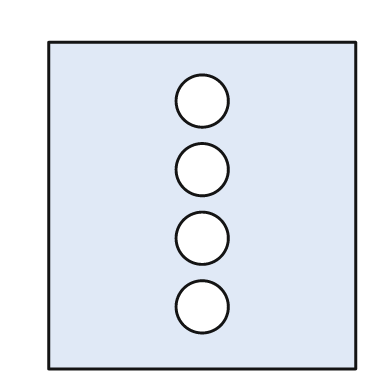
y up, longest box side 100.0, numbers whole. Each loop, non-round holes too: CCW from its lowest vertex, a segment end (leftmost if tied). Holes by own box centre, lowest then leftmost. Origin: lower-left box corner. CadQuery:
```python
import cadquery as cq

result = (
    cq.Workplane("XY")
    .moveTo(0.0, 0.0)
    .lineTo(94.0, 0.0)
    .lineTo(94.0, 100.0)
    .lineTo(0.0, 100.0)
    .close()
    .moveTo(47.0, 19.0)
    .circle(8.0)
    .moveTo(47.0, 40.0)
    .circle(8.0)
    .moveTo(47.0, 61.0)
    .circle(8.0)
    .moveTo(47.0, 82.0)
    .circle(8.0)
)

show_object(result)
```